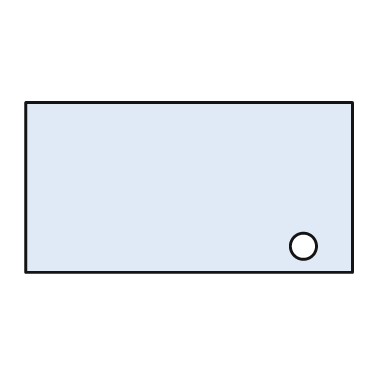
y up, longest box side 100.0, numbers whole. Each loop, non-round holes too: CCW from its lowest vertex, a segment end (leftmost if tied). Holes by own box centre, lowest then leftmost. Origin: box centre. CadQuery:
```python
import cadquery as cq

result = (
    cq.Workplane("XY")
    .moveTo(-50.0, -26.0)
    .lineTo(50.0, -26.0)
    .lineTo(50.0, 26.0)
    .lineTo(-50.0, 26.0)
    .close()
    .moveTo(35.0, -18.0)
    .circle(4.0)
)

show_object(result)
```